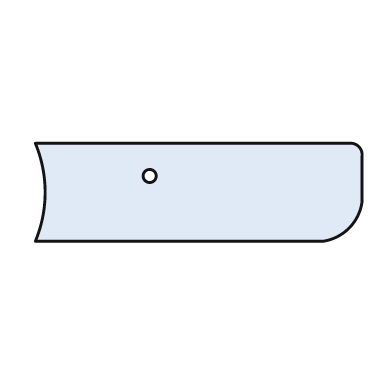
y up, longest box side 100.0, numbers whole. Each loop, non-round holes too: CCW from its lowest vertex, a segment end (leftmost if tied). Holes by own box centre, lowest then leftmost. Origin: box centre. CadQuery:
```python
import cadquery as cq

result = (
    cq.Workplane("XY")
    .moveTo(-50.0, -15.0)
    .lineTo(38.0, -15.0)
    .threePointArc((46.0, -11.0), (50.0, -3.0))
    .lineTo(50.0, 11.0)
    .threePointArc((49.0, 14.0), (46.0, 15.0))
    .lineTo(-50.0, 15.0)
    .threePointArc((-47.0, 0.0), (-50.0, -15.0))
    .close()
    .moveTo(-15.0, 5.0)
    .circle(2.0)
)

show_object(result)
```